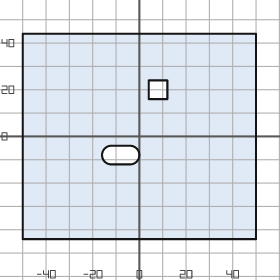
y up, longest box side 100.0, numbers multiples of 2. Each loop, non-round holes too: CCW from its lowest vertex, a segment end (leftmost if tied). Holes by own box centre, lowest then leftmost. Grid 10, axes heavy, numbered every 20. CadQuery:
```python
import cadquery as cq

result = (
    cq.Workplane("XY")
    .moveTo(-50.0, -44.0)
    .lineTo(50.0, -44.0)
    .lineTo(50.0, 44.0)
    .lineTo(-50.0, 44.0)
    .close()
    .moveTo(-12.0, -12.0)
    .lineTo(-4.0, -12.0)
    .threePointArc((0.0, -8.0), (-4.0, -4.0))
    .lineTo(-12.0, -4.0)
    .threePointArc((-16.0, -8.0), (-12.0, -12.0))
    .close()
    .moveTo(4.0, 16.0)
    .lineTo(12.0, 16.0)
    .lineTo(12.0, 24.0)
    .lineTo(4.0, 24.0)
    .close()
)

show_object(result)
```